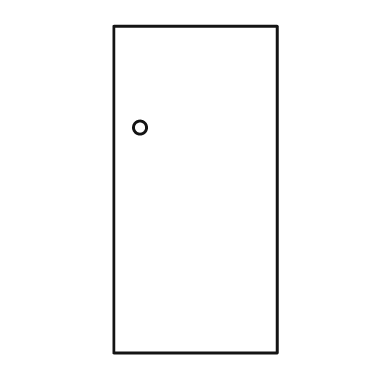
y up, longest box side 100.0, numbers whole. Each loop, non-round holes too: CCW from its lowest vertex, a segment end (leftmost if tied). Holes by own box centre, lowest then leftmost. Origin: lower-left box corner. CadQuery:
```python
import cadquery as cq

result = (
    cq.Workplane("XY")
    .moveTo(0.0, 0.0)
    .lineTo(50.0, 0.0)
    .lineTo(50.0, 100.0)
    .lineTo(0.0, 100.0)
    .close()
    .moveTo(8.0, 69.0)
    .circle(2.0)
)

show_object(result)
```